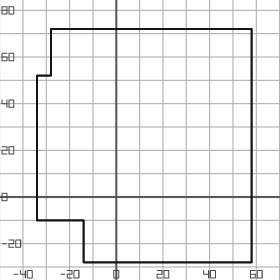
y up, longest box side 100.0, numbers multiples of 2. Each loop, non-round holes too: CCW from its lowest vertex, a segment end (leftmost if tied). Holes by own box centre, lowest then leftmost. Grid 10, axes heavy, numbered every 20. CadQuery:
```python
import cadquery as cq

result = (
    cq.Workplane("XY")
    .moveTo(-14.0, -28.0)
    .lineTo(58.0, -28.0)
    .lineTo(58.0, 72.0)
    .lineTo(-28.0, 72.0)
    .lineTo(-28.0, 52.0)
    .lineTo(-34.0, 52.0)
    .lineTo(-34.0, -10.0)
    .lineTo(-14.0, -10.0)
    .close()
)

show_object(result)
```